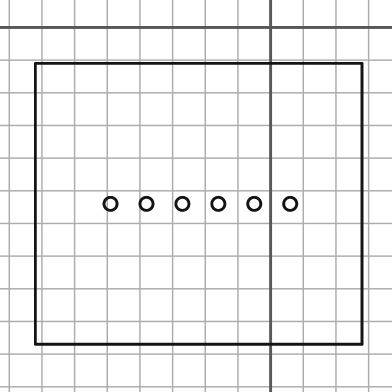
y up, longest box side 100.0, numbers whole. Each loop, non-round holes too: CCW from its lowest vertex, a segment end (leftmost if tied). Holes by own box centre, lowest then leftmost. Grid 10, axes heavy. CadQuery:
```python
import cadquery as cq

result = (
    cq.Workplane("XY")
    .moveTo(-72.0, -97.0)
    .lineTo(28.0, -97.0)
    .lineTo(28.0, -11.0)
    .lineTo(-72.0, -11.0)
    .close()
    .moveTo(-49.0, -54.0)
    .circle(2.0)
    .moveTo(-38.0, -54.0)
    .circle(2.0)
    .moveTo(-27.0, -54.0)
    .circle(2.0)
    .moveTo(-16.0, -54.0)
    .circle(2.0)
    .moveTo(-5.0, -54.0)
    .circle(2.0)
    .moveTo(6.0, -54.0)
    .circle(2.0)
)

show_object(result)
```